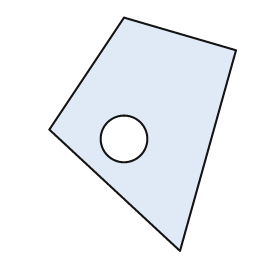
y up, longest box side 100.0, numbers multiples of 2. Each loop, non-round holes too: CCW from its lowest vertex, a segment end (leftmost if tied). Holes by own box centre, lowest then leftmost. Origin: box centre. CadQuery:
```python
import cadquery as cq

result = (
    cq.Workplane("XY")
    .moveTo(16.0, -50.0)
    .lineTo(40.0, 36.0)
    .lineTo(-8.0, 50.0)
    .lineTo(-40.0, 2.0)
    .close()
    .moveTo(-8.0, -2.0)
    .circle(10.0)
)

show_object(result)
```